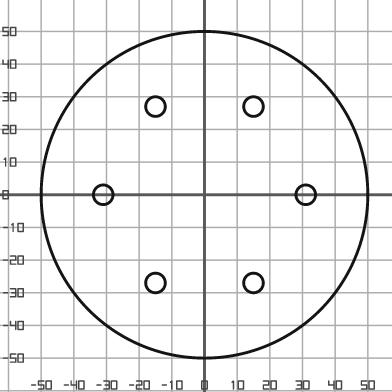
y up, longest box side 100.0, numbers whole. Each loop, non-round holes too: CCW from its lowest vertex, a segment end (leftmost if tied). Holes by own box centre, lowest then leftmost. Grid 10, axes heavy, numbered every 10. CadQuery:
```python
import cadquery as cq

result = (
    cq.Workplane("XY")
    .moveTo(0.0, 0.0)
    .circle(50.0)
    .moveTo(-15.0, -27.0)
    .circle(3.0)
    .moveTo(15.0, -27.0)
    .circle(3.0)
    .moveTo(-31.0, 0.0)
    .circle(3.0)
    .moveTo(31.0, 0.0)
    .circle(3.0)
    .moveTo(-15.0, 27.0)
    .circle(3.0)
    .moveTo(15.0, 27.0)
    .circle(3.0)
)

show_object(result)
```